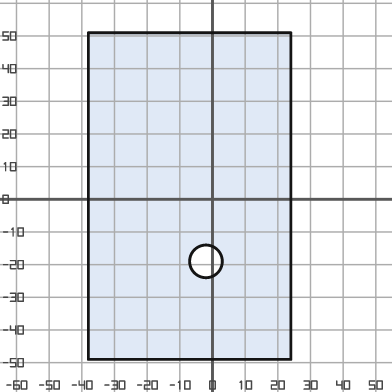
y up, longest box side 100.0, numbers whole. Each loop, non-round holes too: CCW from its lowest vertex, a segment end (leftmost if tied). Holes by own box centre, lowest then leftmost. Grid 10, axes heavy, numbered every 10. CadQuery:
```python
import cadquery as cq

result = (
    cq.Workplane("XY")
    .moveTo(-38.0, -49.0)
    .lineTo(24.0, -49.0)
    .lineTo(24.0, 51.0)
    .lineTo(-38.0, 51.0)
    .close()
    .moveTo(-2.0, -19.0)
    .circle(5.0)
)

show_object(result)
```